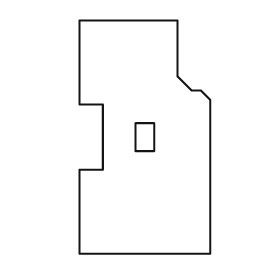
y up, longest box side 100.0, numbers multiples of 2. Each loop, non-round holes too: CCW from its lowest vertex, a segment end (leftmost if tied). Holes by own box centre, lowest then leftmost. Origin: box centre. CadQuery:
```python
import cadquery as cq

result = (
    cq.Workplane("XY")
    .moveTo(-28.0, -50.0)
    .lineTo(28.0, -50.0)
    .lineTo(28.0, 16.0)
    .lineTo(24.0, 20.0)
    .lineTo(20.0, 20.0)
    .lineTo(14.0, 26.0)
    .lineTo(14.0, 50.0)
    .lineTo(-28.0, 50.0)
    .lineTo(-28.0, 14.0)
    .lineTo(-18.0, 14.0)
    .lineTo(-18.0, -14.0)
    .lineTo(-28.0, -14.0)
    .close()
    .moveTo(-4.0, -6.0)
    .lineTo(4.0, -6.0)
    .lineTo(4.0, 6.0)
    .lineTo(-4.0, 6.0)
    .close()
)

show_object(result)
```